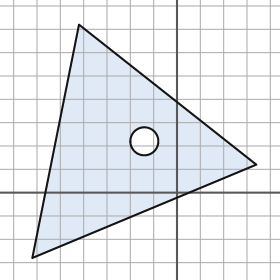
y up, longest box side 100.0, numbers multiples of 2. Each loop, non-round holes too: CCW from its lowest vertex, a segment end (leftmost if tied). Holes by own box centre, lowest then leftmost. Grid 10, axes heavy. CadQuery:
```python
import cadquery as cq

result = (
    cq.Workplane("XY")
    .moveTo(-62.0, -28.0)
    .lineTo(34.0, 12.0)
    .lineTo(-42.0, 72.0)
    .close()
    .moveTo(-14.0, 22.0)
    .circle(6.0)
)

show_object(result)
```